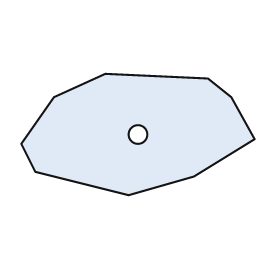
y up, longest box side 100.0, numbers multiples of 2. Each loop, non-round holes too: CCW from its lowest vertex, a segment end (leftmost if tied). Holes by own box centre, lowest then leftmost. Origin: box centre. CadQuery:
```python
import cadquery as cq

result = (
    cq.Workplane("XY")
    .moveTo(-4.0, -26.0)
    .lineTo(24.0, -18.0)
    .lineTo(50.0, -2.0)
    .lineTo(40.0, 16.0)
    .lineTo(30.0, 24.0)
    .lineTo(-14.0, 26.0)
    .lineTo(-36.0, 16.0)
    .lineTo(-50.0, -4.0)
    .lineTo(-44.0, -16.0)
    .close()
    .moveTo(0.0, 0.0)
    .circle(4.0)
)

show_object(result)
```